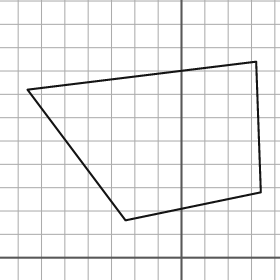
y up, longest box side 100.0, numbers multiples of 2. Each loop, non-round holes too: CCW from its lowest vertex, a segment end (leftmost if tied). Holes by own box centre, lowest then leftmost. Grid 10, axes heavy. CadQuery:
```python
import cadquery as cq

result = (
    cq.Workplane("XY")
    .moveTo(-24.0, 16.0)
    .lineTo(34.0, 28.0)
    .lineTo(32.0, 84.0)
    .lineTo(-66.0, 72.0)
    .close()
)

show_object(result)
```